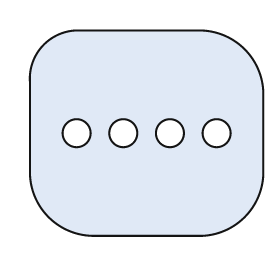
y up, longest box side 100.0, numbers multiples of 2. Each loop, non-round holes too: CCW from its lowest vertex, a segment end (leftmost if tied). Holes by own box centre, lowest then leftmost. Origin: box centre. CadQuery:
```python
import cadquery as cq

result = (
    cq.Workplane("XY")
    .moveTo(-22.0, -44.0)
    .lineTo(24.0, -44.0)
    .threePointArc((42.0, -36.0), (50.0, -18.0))
    .lineTo(50.0, 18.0)
    .threePointArc((42.0, 36.0), (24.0, 44.0))
    .lineTo(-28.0, 44.0)
    .threePointArc((-44.0, 38.0), (-50.0, 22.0))
    .lineTo(-50.0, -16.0)
    .threePointArc((-42.0, -36.0), (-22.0, -44.0))
    .close()
    .moveTo(-30.0, 0.0)
    .circle(6.0)
    .moveTo(-10.0, 0.0)
    .circle(6.0)
    .moveTo(10.0, 0.0)
    .circle(6.0)
    .moveTo(30.0, 0.0)
    .circle(6.0)
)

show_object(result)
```